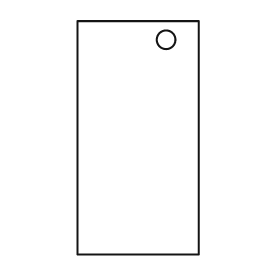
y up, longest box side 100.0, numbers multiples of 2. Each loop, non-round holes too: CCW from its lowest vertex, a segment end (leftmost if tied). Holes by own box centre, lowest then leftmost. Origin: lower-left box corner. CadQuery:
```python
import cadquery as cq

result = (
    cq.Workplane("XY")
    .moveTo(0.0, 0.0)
    .lineTo(52.0, 0.0)
    .lineTo(52.0, 100.0)
    .lineTo(0.0, 100.0)
    .close()
    .moveTo(38.0, 92.0)
    .circle(4.0)
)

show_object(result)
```